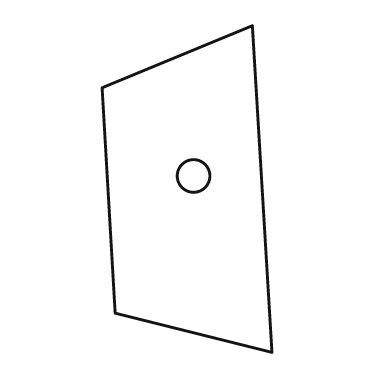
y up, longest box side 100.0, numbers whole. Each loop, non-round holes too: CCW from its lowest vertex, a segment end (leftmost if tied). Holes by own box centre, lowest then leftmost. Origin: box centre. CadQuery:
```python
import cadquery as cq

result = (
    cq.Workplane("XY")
    .moveTo(26.0, -50.0)
    .lineTo(20.0, 50.0)
    .lineTo(-26.0, 31.0)
    .lineTo(-22.0, -38.0)
    .close()
    .moveTo(2.0, 4.0)
    .circle(5.0)
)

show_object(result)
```